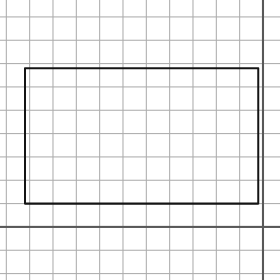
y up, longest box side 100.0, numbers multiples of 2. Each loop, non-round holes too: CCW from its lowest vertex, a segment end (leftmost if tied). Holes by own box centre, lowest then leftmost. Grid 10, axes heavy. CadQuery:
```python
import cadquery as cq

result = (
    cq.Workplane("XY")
    .moveTo(-102.0, 10.0)
    .lineTo(-2.0, 10.0)
    .lineTo(-2.0, 68.0)
    .lineTo(-102.0, 68.0)
    .close()
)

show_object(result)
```